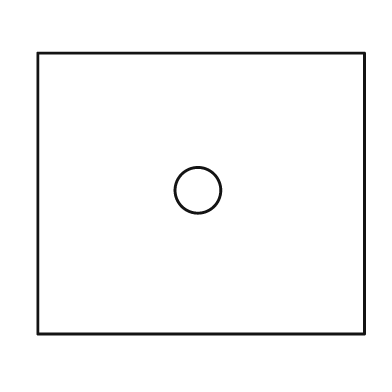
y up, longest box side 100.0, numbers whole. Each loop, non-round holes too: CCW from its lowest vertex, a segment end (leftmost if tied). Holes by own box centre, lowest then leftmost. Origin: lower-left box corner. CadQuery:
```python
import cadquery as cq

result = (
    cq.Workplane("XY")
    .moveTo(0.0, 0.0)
    .lineTo(100.0, 0.0)
    .lineTo(100.0, 86.0)
    .lineTo(0.0, 86.0)
    .close()
    .moveTo(49.0, 44.0)
    .circle(7.0)
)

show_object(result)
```